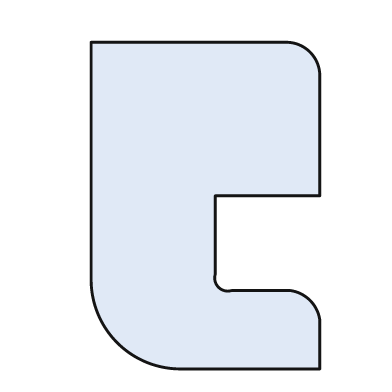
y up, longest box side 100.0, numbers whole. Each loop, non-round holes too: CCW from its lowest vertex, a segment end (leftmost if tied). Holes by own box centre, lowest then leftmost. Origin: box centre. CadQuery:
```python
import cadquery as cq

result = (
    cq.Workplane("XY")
    .moveTo(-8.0, -50.0)
    .lineTo(35.0, -50.0)
    .lineTo(35.0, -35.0)
    .threePointArc((32.0, -29.0), (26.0, -26.0))
    .lineTo(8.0, -26.0)
    .threePointArc((4.0, -25.0), (3.0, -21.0))
    .lineTo(3.0, 3.0)
    .lineTo(35.0, 3.0)
    .lineTo(35.0, 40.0)
    .threePointArc((32.0, 47.0), (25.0, 50.0))
    .lineTo(-35.0, 50.0)
    .lineTo(-35.0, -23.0)
    .threePointArc((-27.0, -42.0), (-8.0, -50.0))
    .close()
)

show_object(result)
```